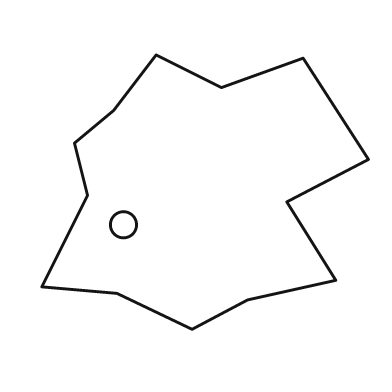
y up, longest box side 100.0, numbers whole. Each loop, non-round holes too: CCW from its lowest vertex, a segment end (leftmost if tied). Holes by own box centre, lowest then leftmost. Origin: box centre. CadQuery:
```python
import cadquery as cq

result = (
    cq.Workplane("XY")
    .moveTo(-4.0, -42.0)
    .lineTo(13.0, -33.0)
    .lineTo(40.0, -27.0)
    .lineTo(25.0, -3.0)
    .lineTo(50.0, 10.0)
    .lineTo(30.0, 41.0)
    .lineTo(5.0, 32.0)
    .lineTo(-15.0, 42.0)
    .lineTo(-28.0, 25.0)
    .lineTo(-40.0, 15.0)
    .lineTo(-36.0, -1.0)
    .lineTo(-50.0, -29.0)
    .lineTo(-27.0, -31.0)
    .close()
    .moveTo(-25.0, -10.0)
    .circle(4.0)
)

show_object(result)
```